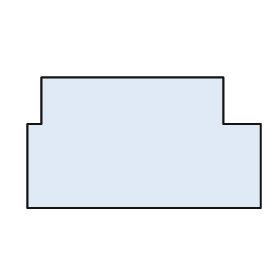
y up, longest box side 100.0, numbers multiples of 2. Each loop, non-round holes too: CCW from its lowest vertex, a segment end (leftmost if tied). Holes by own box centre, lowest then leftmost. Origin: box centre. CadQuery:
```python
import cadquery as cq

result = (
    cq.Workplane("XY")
    .moveTo(-50.0, -28.0)
    .lineTo(50.0, -28.0)
    .lineTo(50.0, 8.0)
    .lineTo(34.0, 8.0)
    .lineTo(34.0, 28.0)
    .lineTo(-44.0, 28.0)
    .lineTo(-44.0, 8.0)
    .lineTo(-50.0, 8.0)
    .close()
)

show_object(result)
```